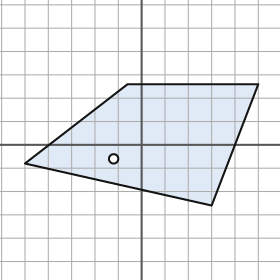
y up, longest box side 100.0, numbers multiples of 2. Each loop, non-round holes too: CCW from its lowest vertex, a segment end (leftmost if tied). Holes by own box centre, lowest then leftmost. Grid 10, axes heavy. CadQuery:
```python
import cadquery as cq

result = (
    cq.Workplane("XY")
    .moveTo(30.0, -26.0)
    .lineTo(50.0, 26.0)
    .lineTo(-6.0, 26.0)
    .lineTo(-50.0, -8.0)
    .close()
    .moveTo(-12.0, -6.0)
    .circle(2.0)
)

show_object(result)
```